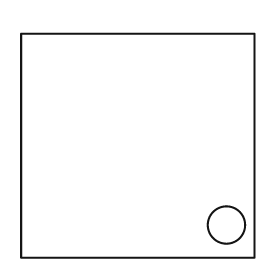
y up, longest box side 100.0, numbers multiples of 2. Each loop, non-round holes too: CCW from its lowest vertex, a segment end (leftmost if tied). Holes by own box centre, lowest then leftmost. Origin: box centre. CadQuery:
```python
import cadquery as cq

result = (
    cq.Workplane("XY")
    .moveTo(-50.0, -48.0)
    .lineTo(50.0, -48.0)
    .lineTo(50.0, 48.0)
    .lineTo(-50.0, 48.0)
    .close()
    .moveTo(38.0, -34.0)
    .circle(8.0)
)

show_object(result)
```